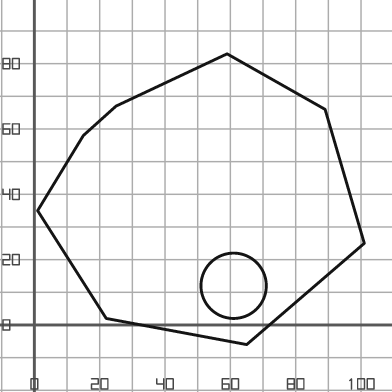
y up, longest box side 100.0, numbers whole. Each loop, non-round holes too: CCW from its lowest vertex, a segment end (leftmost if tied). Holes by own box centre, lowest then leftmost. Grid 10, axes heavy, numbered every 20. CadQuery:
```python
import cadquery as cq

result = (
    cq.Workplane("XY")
    .moveTo(65.0, -6.0)
    .lineTo(101.0, 25.0)
    .lineTo(89.0, 66.0)
    .lineTo(59.0, 83.0)
    .lineTo(25.0, 67.0)
    .lineTo(15.0, 58.0)
    .lineTo(1.0, 35.0)
    .lineTo(22.0, 2.0)
    .close()
    .moveTo(61.0, 12.0)
    .circle(10.0)
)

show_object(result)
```